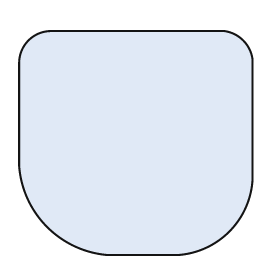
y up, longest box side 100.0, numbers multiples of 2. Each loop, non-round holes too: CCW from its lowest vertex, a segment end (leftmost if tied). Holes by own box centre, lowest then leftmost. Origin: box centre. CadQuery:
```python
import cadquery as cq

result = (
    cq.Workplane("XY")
    .moveTo(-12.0, -48.0)
    .lineTo(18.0, -48.0)
    .threePointArc((40.0, -38.0), (50.0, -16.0))
    .lineTo(50.0, 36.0)
    .threePointArc((46.0, 44.0), (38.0, 48.0))
    .lineTo(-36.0, 48.0)
    .threePointArc((-46.0, 44.0), (-50.0, 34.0))
    .lineTo(-50.0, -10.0)
    .threePointArc((-38.0, -36.0), (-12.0, -48.0))
    .close()
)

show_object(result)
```